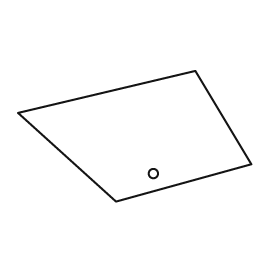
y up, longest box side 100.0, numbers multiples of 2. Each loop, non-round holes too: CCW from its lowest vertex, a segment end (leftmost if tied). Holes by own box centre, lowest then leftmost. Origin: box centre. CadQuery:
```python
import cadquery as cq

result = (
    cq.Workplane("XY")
    .moveTo(-8.0, -28.0)
    .lineTo(50.0, -12.0)
    .lineTo(26.0, 28.0)
    .lineTo(-50.0, 10.0)
    .close()
    .moveTo(8.0, -16.0)
    .circle(2.0)
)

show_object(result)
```